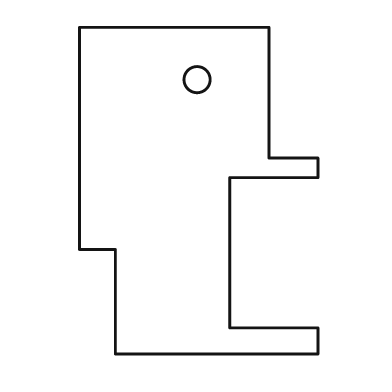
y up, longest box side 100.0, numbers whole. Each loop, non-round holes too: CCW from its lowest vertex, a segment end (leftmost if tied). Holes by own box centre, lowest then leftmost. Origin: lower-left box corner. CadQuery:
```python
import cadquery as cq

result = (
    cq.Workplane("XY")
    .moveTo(11.0, 0.0)
    .lineTo(73.0, 0.0)
    .lineTo(73.0, 8.0)
    .lineTo(46.0, 8.0)
    .lineTo(46.0, 54.0)
    .lineTo(73.0, 54.0)
    .lineTo(73.0, 60.0)
    .lineTo(58.0, 60.0)
    .lineTo(58.0, 100.0)
    .lineTo(0.0, 100.0)
    .lineTo(0.0, 32.0)
    .lineTo(11.0, 32.0)
    .close()
    .moveTo(36.0, 84.0)
    .circle(4.0)
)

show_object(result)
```